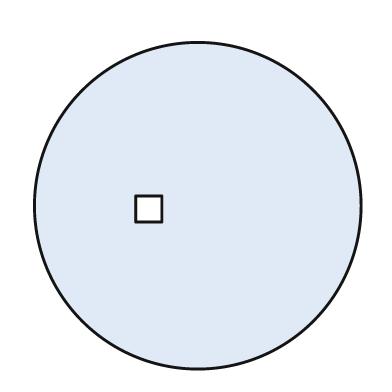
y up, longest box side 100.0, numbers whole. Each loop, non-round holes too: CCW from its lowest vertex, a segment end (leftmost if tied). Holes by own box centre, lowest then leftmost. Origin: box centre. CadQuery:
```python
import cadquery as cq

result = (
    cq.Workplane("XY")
    .moveTo(0.0, 0.0)
    .circle(50.0)
    .moveTo(-19.0, -5.0)
    .lineTo(-11.0, -5.0)
    .lineTo(-11.0, 3.0)
    .lineTo(-19.0, 3.0)
    .close()
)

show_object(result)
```